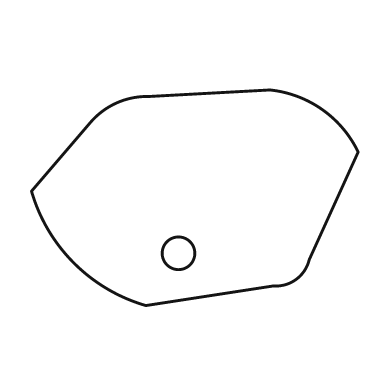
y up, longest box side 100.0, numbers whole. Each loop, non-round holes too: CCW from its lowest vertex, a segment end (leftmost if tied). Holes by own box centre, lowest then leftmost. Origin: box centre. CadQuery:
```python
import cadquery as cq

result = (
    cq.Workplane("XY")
    .moveTo(-15.0, -33.0)
    .lineTo(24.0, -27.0)
    .threePointArc((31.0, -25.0), (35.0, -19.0))
    .lineTo(50.0, 14.0)
    .threePointArc((39.0, 27.0), (23.0, 33.0))
    .lineTo(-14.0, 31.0)
    .threePointArc((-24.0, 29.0), (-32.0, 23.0))
    .lineTo(-50.0, 2.0)
    .threePointArc((-37.0, -20.0), (-15.0, -33.0))
    .close()
    .moveTo(-5.0, -17.0)
    .circle(5.0)
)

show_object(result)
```